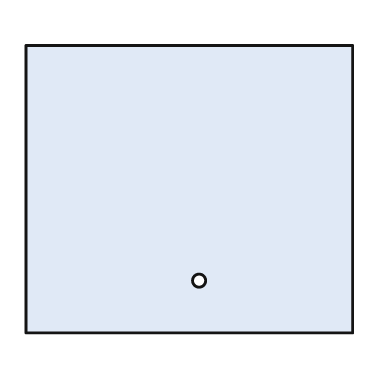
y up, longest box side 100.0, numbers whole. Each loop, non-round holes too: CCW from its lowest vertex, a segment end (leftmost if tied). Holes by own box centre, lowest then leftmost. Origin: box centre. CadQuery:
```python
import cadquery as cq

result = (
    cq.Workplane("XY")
    .moveTo(-50.0, -44.0)
    .lineTo(50.0, -44.0)
    .lineTo(50.0, 44.0)
    .lineTo(-50.0, 44.0)
    .close()
    .moveTo(3.0, -28.0)
    .circle(2.0)
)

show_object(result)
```